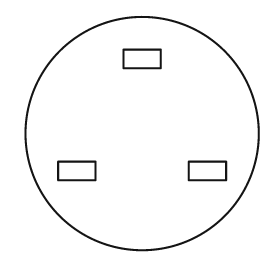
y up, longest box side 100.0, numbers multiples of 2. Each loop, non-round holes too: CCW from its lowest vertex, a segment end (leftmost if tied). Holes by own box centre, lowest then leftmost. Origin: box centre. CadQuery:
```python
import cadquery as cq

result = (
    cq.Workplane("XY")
    .moveTo(0.0, 0.0)
    .circle(50.0)
    .moveTo(-36.0, -20.0)
    .lineTo(-20.0, -20.0)
    .lineTo(-20.0, -12.0)
    .lineTo(-36.0, -12.0)
    .close()
    .moveTo(20.0, -20.0)
    .lineTo(36.0, -20.0)
    .lineTo(36.0, -12.0)
    .lineTo(20.0, -12.0)
    .close()
    .moveTo(-8.0, 28.0)
    .lineTo(8.0, 28.0)
    .lineTo(8.0, 36.0)
    .lineTo(-8.0, 36.0)
    .close()
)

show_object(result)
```